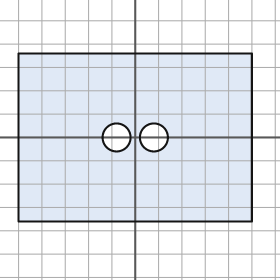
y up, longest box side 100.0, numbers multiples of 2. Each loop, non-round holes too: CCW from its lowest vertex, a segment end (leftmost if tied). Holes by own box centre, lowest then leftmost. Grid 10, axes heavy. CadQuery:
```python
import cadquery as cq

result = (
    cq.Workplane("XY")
    .moveTo(-50.0, -36.0)
    .lineTo(50.0, -36.0)
    .lineTo(50.0, 36.0)
    .lineTo(-50.0, 36.0)
    .close()
    .moveTo(-8.0, 0.0)
    .circle(6.0)
    .moveTo(8.0, 0.0)
    .circle(6.0)
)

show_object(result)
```